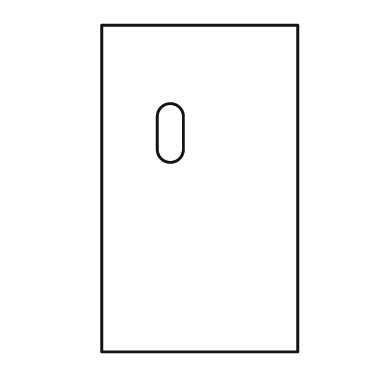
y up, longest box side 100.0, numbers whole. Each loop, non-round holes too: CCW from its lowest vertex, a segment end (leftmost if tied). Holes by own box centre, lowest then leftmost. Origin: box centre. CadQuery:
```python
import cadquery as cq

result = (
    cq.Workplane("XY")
    .moveTo(-30.0, -50.0)
    .lineTo(30.0, -50.0)
    .lineTo(30.0, 50.0)
    .lineTo(-30.0, 50.0)
    .close()
    .moveTo(-13.0, 12.0)
    .threePointArc((-9.0, 8.0), (-5.0, 12.0))
    .lineTo(-5.0, 22.0)
    .threePointArc((-9.0, 26.0), (-13.0, 22.0))
    .close()
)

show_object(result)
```